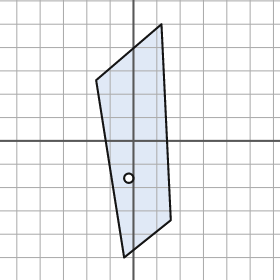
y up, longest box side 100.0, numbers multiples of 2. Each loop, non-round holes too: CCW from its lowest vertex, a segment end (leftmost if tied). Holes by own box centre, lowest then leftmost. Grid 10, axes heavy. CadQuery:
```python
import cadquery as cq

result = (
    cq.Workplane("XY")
    .moveTo(-4.0, -50.0)
    .lineTo(16.0, -34.0)
    .lineTo(12.0, 50.0)
    .lineTo(-16.0, 26.0)
    .close()
    .moveTo(-2.0, -16.0)
    .circle(2.0)
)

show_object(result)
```